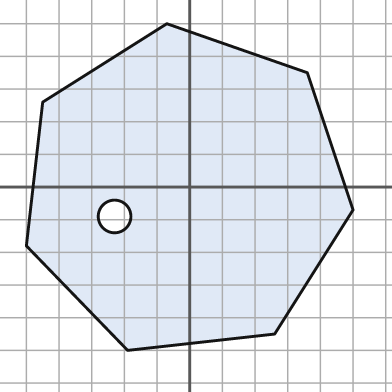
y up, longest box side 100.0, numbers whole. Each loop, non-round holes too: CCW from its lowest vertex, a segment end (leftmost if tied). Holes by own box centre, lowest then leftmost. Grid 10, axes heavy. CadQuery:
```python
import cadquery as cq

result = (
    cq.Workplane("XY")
    .moveTo(-19.0, -50.0)
    .lineTo(26.0, -45.0)
    .lineTo(50.0, -7.0)
    .lineTo(36.0, 35.0)
    .lineTo(-7.0, 50.0)
    .lineTo(-45.0, 26.0)
    .lineTo(-50.0, -18.0)
    .close()
    .moveTo(-23.0, -9.0)
    .circle(5.0)
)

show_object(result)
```